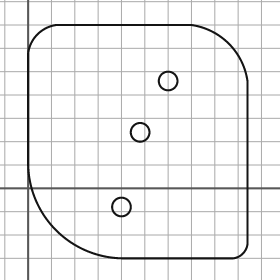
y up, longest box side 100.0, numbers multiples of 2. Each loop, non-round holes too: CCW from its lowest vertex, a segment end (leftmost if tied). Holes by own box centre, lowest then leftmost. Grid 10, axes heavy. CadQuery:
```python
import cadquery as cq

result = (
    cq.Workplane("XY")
    .moveTo(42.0, -30.0)
    .lineTo(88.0, -30.0)
    .threePointArc((92.0, -28.0), (94.0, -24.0))
    .lineTo(94.0, 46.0)
    .threePointArc((86.0, 62.0), (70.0, 70.0))
    .lineTo(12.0, 70.0)
    .threePointArc((4.0, 66.0), (0.0, 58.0))
    .lineTo(0.0, 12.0)
    .threePointArc((12.0, -18.0), (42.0, -30.0))
    .close()
    .moveTo(40.0, -8.0)
    .circle(4.0)
    .moveTo(48.0, 24.0)
    .circle(4.0)
    .moveTo(60.0, 46.0)
    .circle(4.0)
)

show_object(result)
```